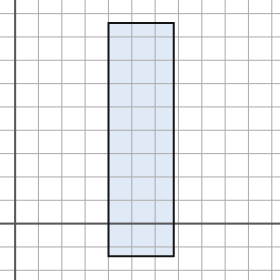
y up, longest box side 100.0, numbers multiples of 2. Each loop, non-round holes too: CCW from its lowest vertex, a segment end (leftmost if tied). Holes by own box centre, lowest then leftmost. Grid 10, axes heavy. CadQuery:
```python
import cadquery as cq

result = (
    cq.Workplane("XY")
    .moveTo(40.0, -14.0)
    .lineTo(68.0, -14.0)
    .lineTo(68.0, 86.0)
    .lineTo(40.0, 86.0)
    .close()
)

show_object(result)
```